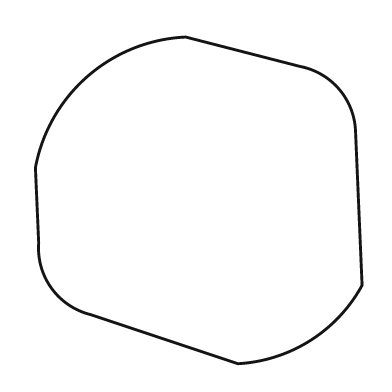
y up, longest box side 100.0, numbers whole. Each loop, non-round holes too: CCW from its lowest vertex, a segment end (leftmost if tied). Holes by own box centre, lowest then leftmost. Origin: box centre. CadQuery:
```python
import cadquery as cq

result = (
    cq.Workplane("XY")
    .moveTo(12.0, -50.0)
    .threePointArc((34.0, -43.0), (50.0, -26.0))
    .lineTo(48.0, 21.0)
    .threePointArc((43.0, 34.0), (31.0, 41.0))
    .lineTo(-4.0, 50.0)
    .threePointArc((-34.0, 38.0), (-50.0, 10.0))
    .lineTo(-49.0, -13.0)
    .threePointArc((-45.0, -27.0), (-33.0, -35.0))
    .close()
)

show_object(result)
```